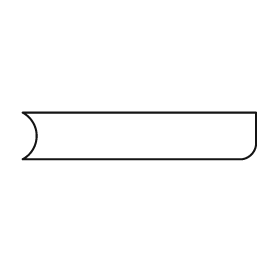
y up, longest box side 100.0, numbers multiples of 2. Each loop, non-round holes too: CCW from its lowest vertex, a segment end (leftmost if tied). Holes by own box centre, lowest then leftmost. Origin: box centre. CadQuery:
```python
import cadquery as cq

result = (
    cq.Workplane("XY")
    .moveTo(-50.0, -10.0)
    .lineTo(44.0, -10.0)
    .threePointArc((48.0, -8.0), (50.0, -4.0))
    .lineTo(50.0, 10.0)
    .lineTo(-50.0, 10.0)
    .threePointArc((-44.0, 0.0), (-50.0, -10.0))
    .close()
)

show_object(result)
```